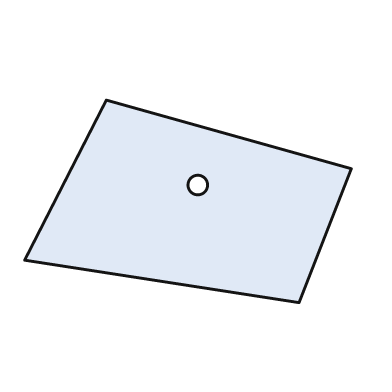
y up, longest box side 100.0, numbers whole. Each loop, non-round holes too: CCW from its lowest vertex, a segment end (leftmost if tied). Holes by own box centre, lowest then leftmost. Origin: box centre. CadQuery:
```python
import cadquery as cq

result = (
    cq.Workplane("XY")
    .moveTo(34.0, -31.0)
    .lineTo(50.0, 10.0)
    .lineTo(-25.0, 31.0)
    .lineTo(-50.0, -18.0)
    .close()
    .moveTo(3.0, 5.0)
    .circle(3.0)
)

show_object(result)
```